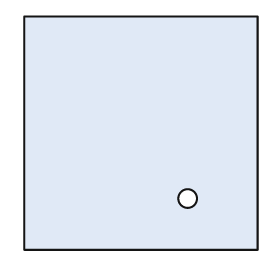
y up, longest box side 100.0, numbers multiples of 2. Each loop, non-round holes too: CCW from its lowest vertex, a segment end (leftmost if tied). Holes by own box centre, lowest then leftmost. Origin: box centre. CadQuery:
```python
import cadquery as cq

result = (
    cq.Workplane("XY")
    .moveTo(-50.0, -50.0)
    .lineTo(50.0, -50.0)
    .lineTo(50.0, 50.0)
    .lineTo(-50.0, 50.0)
    .close()
    .moveTo(20.0, -28.0)
    .circle(4.0)
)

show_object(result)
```